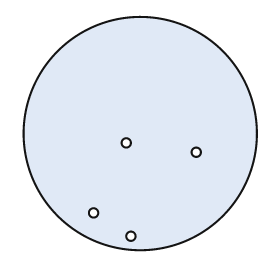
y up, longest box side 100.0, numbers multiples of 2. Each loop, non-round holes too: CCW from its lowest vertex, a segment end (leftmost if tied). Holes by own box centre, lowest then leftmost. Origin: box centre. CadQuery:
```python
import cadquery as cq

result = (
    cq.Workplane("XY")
    .moveTo(0.0, 0.0)
    .circle(50.0)
    .moveTo(-4.0, -44.0)
    .circle(2.0)
    .moveTo(-20.0, -34.0)
    .circle(2.0)
    .moveTo(24.0, -8.0)
    .circle(2.0)
    .moveTo(-6.0, -4.0)
    .circle(2.0)
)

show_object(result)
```